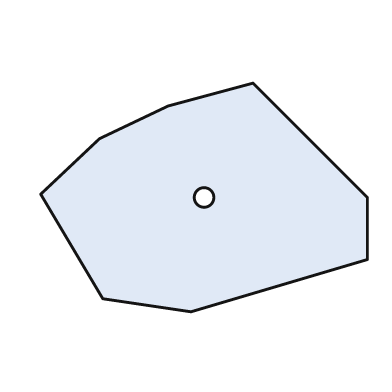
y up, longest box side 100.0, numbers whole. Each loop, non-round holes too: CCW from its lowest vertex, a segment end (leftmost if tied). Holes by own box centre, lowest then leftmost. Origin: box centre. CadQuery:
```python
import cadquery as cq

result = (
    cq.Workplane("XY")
    .moveTo(-4.0, -35.0)
    .lineTo(50.0, -19.0)
    .lineTo(50.0, 0.0)
    .lineTo(15.0, 35.0)
    .lineTo(-11.0, 28.0)
    .lineTo(-32.0, 18.0)
    .lineTo(-50.0, 1.0)
    .lineTo(-31.0, -31.0)
    .close()
    .moveTo(0.0, 0.0)
    .circle(3.0)
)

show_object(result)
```